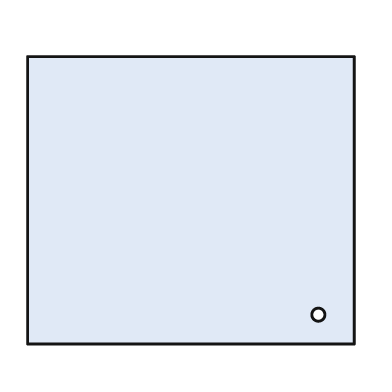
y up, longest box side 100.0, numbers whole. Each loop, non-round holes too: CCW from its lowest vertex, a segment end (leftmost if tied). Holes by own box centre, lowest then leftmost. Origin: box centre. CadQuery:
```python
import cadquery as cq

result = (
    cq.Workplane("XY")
    .moveTo(-50.0, -44.0)
    .lineTo(50.0, -44.0)
    .lineTo(50.0, 44.0)
    .lineTo(-50.0, 44.0)
    .close()
    .moveTo(39.0, -35.0)
    .circle(2.0)
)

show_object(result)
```